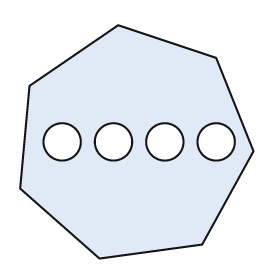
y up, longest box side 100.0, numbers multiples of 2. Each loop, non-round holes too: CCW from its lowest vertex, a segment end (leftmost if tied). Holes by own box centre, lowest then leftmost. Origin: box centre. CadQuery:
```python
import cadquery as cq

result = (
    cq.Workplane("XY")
    .moveTo(-16.0, -50.0)
    .lineTo(28.0, -44.0)
    .lineTo(50.0, -4.0)
    .lineTo(34.0, 36.0)
    .lineTo(-8.0, 50.0)
    .lineTo(-46.0, 24.0)
    .lineTo(-50.0, -20.0)
    .close()
    .moveTo(-32.0, 0.0)
    .circle(8.0)
    .moveTo(-10.0, 0.0)
    .circle(8.0)
    .moveTo(12.0, 0.0)
    .circle(8.0)
    .moveTo(34.0, 0.0)
    .circle(8.0)
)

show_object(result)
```